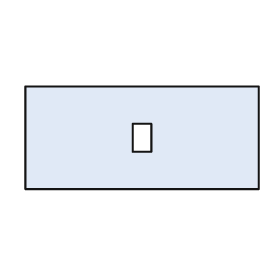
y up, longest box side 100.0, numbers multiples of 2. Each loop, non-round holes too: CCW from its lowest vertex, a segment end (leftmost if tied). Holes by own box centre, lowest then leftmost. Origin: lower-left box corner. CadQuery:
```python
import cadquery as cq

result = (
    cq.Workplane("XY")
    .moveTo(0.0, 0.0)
    .lineTo(100.0, 0.0)
    .lineTo(100.0, 44.0)
    .lineTo(0.0, 44.0)
    .close()
    .moveTo(46.0, 16.0)
    .lineTo(54.0, 16.0)
    .lineTo(54.0, 28.0)
    .lineTo(46.0, 28.0)
    .close()
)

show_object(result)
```